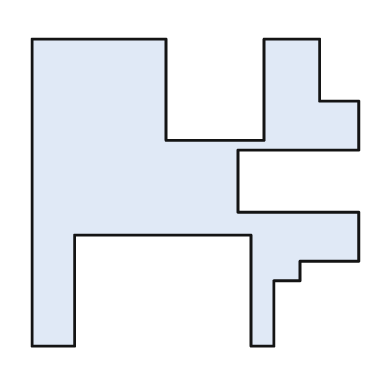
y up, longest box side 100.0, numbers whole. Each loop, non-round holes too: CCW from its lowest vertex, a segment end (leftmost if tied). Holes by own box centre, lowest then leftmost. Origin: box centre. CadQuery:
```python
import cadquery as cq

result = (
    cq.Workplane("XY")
    .moveTo(-50.0, -47.0)
    .lineTo(-37.0, -47.0)
    .lineTo(-37.0, -13.0)
    .lineTo(17.0, -13.0)
    .lineTo(17.0, -47.0)
    .lineTo(24.0, -47.0)
    .lineTo(24.0, -27.0)
    .lineTo(32.0, -27.0)
    .lineTo(32.0, -21.0)
    .lineTo(50.0, -21.0)
    .lineTo(50.0, -6.0)
    .lineTo(13.0, -6.0)
    .lineTo(13.0, 13.0)
    .lineTo(50.0, 13.0)
    .lineTo(50.0, 28.0)
    .lineTo(38.0, 28.0)
    .lineTo(38.0, 47.0)
    .lineTo(21.0, 47.0)
    .lineTo(21.0, 16.0)
    .lineTo(-9.0, 16.0)
    .lineTo(-9.0, 47.0)
    .lineTo(-50.0, 47.0)
    .close()
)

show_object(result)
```